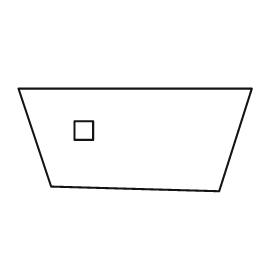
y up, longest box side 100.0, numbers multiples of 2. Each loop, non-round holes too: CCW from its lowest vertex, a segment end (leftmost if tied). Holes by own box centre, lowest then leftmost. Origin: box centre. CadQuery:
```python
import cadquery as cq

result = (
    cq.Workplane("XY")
    .moveTo(36.0, -22.0)
    .lineTo(50.0, 22.0)
    .lineTo(-50.0, 22.0)
    .lineTo(-36.0, -20.0)
    .close()
    .moveTo(-26.0, 0.0)
    .lineTo(-18.0, 0.0)
    .lineTo(-18.0, 8.0)
    .lineTo(-26.0, 8.0)
    .close()
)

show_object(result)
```